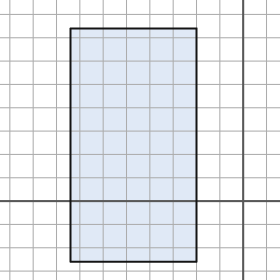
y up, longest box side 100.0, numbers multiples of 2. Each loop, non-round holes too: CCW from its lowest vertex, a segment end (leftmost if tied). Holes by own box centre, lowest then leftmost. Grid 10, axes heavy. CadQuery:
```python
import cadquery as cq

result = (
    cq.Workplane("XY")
    .moveTo(-74.0, -26.0)
    .lineTo(-20.0, -26.0)
    .lineTo(-20.0, 74.0)
    .lineTo(-74.0, 74.0)
    .close()
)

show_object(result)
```